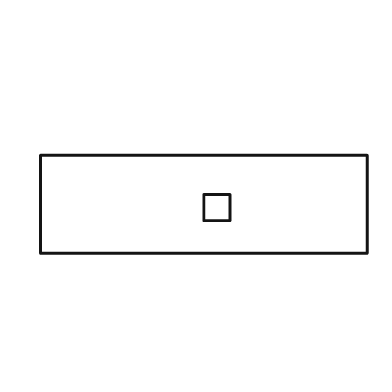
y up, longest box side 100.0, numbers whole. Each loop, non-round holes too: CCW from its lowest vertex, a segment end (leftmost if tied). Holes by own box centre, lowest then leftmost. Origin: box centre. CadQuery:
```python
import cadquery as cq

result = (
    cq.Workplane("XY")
    .moveTo(-50.0, -15.0)
    .lineTo(50.0, -15.0)
    .lineTo(50.0, 15.0)
    .lineTo(-50.0, 15.0)
    .close()
    .moveTo(0.0, -5.0)
    .lineTo(8.0, -5.0)
    .lineTo(8.0, 3.0)
    .lineTo(0.0, 3.0)
    .close()
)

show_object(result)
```